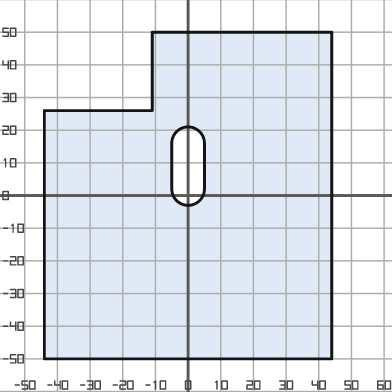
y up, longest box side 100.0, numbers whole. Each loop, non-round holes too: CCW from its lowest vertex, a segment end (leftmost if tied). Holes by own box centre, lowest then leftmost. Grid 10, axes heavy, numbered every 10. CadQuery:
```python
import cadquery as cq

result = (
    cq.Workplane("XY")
    .moveTo(-44.0, -50.0)
    .lineTo(44.0, -50.0)
    .lineTo(44.0, 50.0)
    .lineTo(-11.0, 50.0)
    .lineTo(-11.0, 26.0)
    .lineTo(-44.0, 26.0)
    .close()
    .moveTo(-5.0, 2.0)
    .threePointArc((0.0, -3.0), (5.0, 2.0))
    .lineTo(5.0, 16.0)
    .threePointArc((0.0, 21.0), (-5.0, 16.0))
    .close()
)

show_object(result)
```